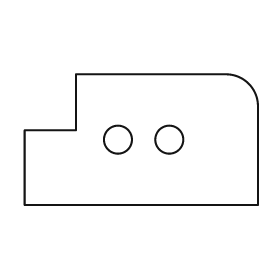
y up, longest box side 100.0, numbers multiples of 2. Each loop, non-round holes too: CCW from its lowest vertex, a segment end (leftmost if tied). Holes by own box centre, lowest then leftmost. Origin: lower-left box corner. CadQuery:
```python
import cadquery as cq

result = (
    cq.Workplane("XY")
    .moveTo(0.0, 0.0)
    .lineTo(100.0, 0.0)
    .lineTo(100.0, 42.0)
    .threePointArc((96.0, 52.0), (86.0, 56.0))
    .lineTo(22.0, 56.0)
    .lineTo(22.0, 32.0)
    .lineTo(0.0, 32.0)
    .close()
    .moveTo(40.0, 28.0)
    .circle(6.0)
    .moveTo(62.0, 28.0)
    .circle(6.0)
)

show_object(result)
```